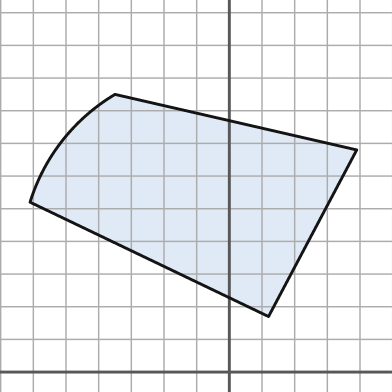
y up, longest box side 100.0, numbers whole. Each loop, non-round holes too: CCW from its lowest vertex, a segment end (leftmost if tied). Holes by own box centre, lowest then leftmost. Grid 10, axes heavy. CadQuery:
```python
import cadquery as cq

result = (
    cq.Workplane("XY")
    .moveTo(12.0, 17.0)
    .lineTo(39.0, 68.0)
    .lineTo(-35.0, 85.0)
    .threePointArc((-51.0, 71.0), (-61.0, 52.0))
    .close()
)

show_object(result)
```